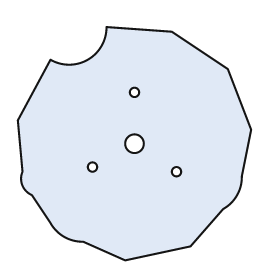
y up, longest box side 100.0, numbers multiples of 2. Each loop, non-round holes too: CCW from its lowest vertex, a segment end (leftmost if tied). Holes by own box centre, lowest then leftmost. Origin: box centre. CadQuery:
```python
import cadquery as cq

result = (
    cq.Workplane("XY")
    .moveTo(-4.0, -50.0)
    .lineTo(24.0, -44.0)
    .lineTo(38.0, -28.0)
    .threePointArc((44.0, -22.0), (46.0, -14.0))
    .lineTo(50.0, 6.0)
    .lineTo(40.0, 32.0)
    .lineTo(16.0, 48.0)
    .lineTo(-12.0, 50.0)
    .threePointArc((-20.0, 36.0), (-36.0, 36.0))
    .lineTo(-50.0, 10.0)
    .lineTo(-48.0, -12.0)
    .threePointArc((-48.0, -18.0), (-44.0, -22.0))
    .lineTo(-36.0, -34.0)
    .threePointArc((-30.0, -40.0), (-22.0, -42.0))
    .close()
    .moveTo(18.0, -12.0)
    .circle(2.0)
    .moveTo(-18.0, -10.0)
    .circle(2.0)
    .moveTo(0.0, 0.0)
    .circle(4.0)
    .moveTo(0.0, 22.0)
    .circle(2.0)
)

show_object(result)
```